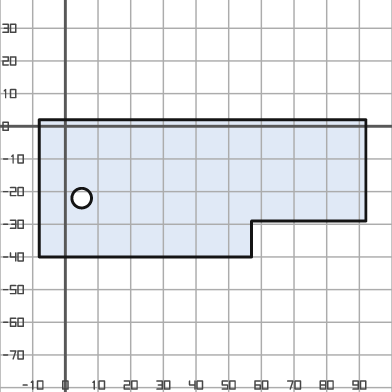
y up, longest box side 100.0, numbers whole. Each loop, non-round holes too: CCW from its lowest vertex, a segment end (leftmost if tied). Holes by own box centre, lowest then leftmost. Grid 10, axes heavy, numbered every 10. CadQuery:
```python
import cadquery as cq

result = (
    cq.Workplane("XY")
    .moveTo(-8.0, -40.0)
    .lineTo(57.0, -40.0)
    .lineTo(57.0, -29.0)
    .lineTo(92.0, -29.0)
    .lineTo(92.0, 2.0)
    .lineTo(-8.0, 2.0)
    .close()
    .moveTo(5.0, -22.0)
    .circle(3.0)
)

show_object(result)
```